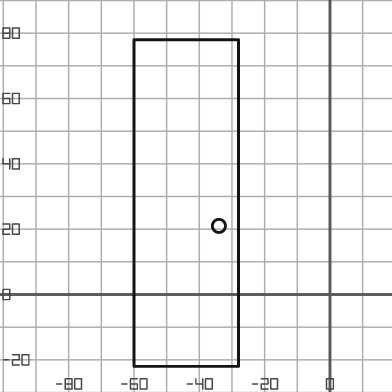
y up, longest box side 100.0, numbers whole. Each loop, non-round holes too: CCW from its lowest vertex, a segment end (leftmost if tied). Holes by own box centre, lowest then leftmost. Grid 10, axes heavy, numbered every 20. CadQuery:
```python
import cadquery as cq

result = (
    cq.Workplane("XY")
    .moveTo(-60.0, -22.0)
    .lineTo(-28.0, -22.0)
    .lineTo(-28.0, 78.0)
    .lineTo(-60.0, 78.0)
    .close()
    .moveTo(-34.0, 21.0)
    .circle(2.0)
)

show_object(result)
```